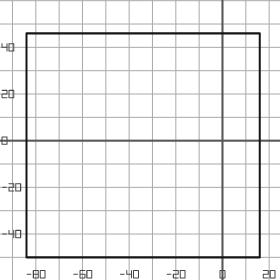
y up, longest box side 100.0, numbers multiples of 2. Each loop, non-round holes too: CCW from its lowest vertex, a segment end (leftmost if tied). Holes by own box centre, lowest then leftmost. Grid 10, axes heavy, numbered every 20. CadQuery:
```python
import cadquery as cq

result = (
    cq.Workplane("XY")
    .moveTo(-84.0, -50.0)
    .lineTo(16.0, -50.0)
    .lineTo(16.0, 46.0)
    .lineTo(-84.0, 46.0)
    .close()
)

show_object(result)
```